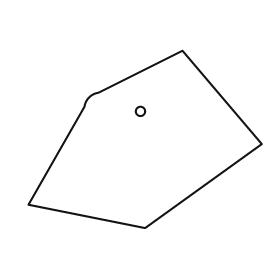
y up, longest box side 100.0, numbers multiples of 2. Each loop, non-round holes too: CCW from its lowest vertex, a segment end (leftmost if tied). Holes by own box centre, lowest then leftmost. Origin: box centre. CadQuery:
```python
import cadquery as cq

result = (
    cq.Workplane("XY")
    .moveTo(0.0, -38.0)
    .lineTo(50.0, -2.0)
    .lineTo(16.0, 38.0)
    .lineTo(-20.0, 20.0)
    .threePointArc((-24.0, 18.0), (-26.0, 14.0))
    .lineTo(-50.0, -28.0)
    .close()
    .moveTo(-2.0, 12.0)
    .circle(2.0)
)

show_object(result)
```